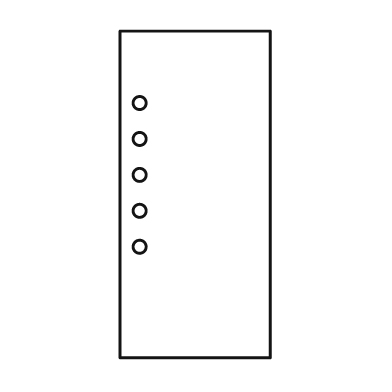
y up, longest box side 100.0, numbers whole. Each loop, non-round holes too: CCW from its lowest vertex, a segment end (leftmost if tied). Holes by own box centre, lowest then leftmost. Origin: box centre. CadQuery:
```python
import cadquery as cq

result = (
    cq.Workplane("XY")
    .moveTo(-23.0, -50.0)
    .lineTo(23.0, -50.0)
    .lineTo(23.0, 50.0)
    .lineTo(-23.0, 50.0)
    .close()
    .moveTo(-17.0, -16.0)
    .circle(2.0)
    .moveTo(-17.0, -5.0)
    .circle(2.0)
    .moveTo(-17.0, 6.0)
    .circle(2.0)
    .moveTo(-17.0, 17.0)
    .circle(2.0)
    .moveTo(-17.0, 28.0)
    .circle(2.0)
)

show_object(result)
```